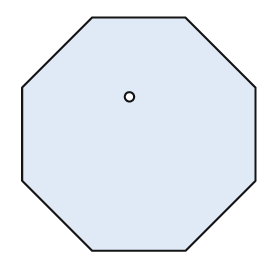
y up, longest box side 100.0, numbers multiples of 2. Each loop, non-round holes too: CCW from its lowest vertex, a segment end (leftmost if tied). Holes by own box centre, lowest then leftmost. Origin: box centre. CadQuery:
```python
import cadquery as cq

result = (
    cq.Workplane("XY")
    .moveTo(-20.0, -50.0)
    .lineTo(20.0, -50.0)
    .lineTo(50.0, -20.0)
    .lineTo(50.0, 20.0)
    .lineTo(20.0, 50.0)
    .lineTo(-20.0, 50.0)
    .lineTo(-50.0, 20.0)
    .lineTo(-50.0, -20.0)
    .close()
    .moveTo(-4.0, 16.0)
    .circle(2.0)
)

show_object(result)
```